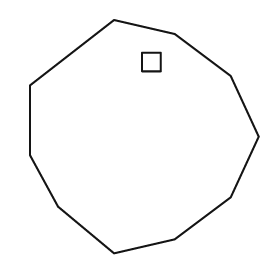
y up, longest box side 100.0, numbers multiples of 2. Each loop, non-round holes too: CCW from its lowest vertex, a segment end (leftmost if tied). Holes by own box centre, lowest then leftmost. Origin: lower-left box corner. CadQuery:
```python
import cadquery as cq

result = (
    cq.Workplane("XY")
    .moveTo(36.0, 0.0)
    .lineTo(62.0, 6.0)
    .lineTo(86.0, 24.0)
    .lineTo(98.0, 50.0)
    .lineTo(86.0, 76.0)
    .lineTo(62.0, 94.0)
    .lineTo(36.0, 100.0)
    .lineTo(0.0, 72.0)
    .lineTo(0.0, 42.0)
    .lineTo(12.0, 20.0)
    .close()
    .moveTo(48.0, 78.0)
    .lineTo(56.0, 78.0)
    .lineTo(56.0, 86.0)
    .lineTo(48.0, 86.0)
    .close()
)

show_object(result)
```